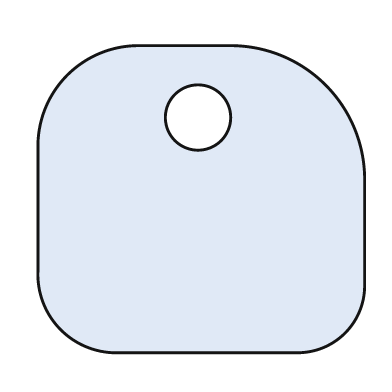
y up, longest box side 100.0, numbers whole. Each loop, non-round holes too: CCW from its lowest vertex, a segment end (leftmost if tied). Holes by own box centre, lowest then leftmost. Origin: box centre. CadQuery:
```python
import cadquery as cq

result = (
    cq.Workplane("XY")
    .moveTo(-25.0, -47.0)
    .lineTo(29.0, -47.0)
    .threePointArc((44.0, -41.0), (50.0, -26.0))
    .lineTo(50.0, 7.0)
    .threePointArc((38.0, 35.0), (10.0, 47.0))
    .lineTo(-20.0, 47.0)
    .threePointArc((-41.0, 38.0), (-50.0, 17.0))
    .lineTo(-50.0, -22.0)
    .threePointArc((-43.0, -40.0), (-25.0, -47.0))
    .close()
    .moveTo(-1.0, 25.0)
    .circle(10.0)
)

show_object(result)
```